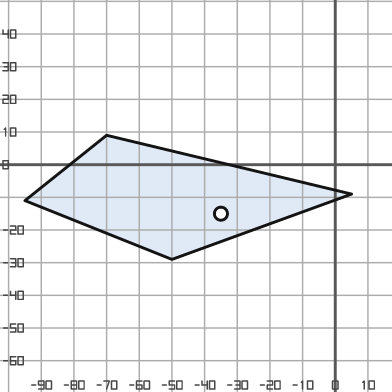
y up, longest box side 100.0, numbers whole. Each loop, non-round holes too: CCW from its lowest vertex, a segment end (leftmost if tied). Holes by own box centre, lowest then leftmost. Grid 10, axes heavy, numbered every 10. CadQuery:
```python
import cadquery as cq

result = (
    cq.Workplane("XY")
    .moveTo(-50.0, -29.0)
    .lineTo(5.0, -9.0)
    .lineTo(-70.0, 9.0)
    .lineTo(-95.0, -11.0)
    .close()
    .moveTo(-35.0, -15.0)
    .circle(2.0)
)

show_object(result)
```